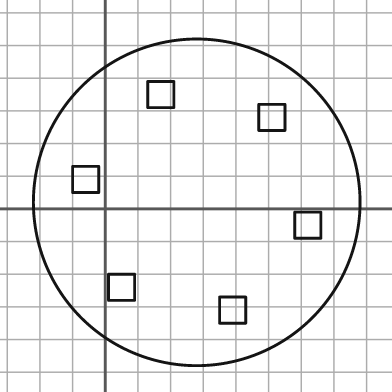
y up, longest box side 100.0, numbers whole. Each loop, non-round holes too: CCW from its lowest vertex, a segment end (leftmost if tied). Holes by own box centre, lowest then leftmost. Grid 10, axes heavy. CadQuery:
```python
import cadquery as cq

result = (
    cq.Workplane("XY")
    .moveTo(28.0, 2.0)
    .circle(50.0)
    .moveTo(35.0, -35.0)
    .lineTo(43.0, -35.0)
    .lineTo(43.0, -27.0)
    .lineTo(35.0, -27.0)
    .close()
    .moveTo(1.0, -28.0)
    .lineTo(9.0, -28.0)
    .lineTo(9.0, -20.0)
    .lineTo(1.0, -20.0)
    .close()
    .moveTo(58.0, -9.0)
    .lineTo(66.0, -9.0)
    .lineTo(66.0, -1.0)
    .lineTo(58.0, -1.0)
    .close()
    .moveTo(-10.0, 5.0)
    .lineTo(-2.0, 5.0)
    .lineTo(-2.0, 13.0)
    .lineTo(-10.0, 13.0)
    .close()
    .moveTo(47.0, 24.0)
    .lineTo(55.0, 24.0)
    .lineTo(55.0, 32.0)
    .lineTo(47.0, 32.0)
    .close()
    .moveTo(13.0, 31.0)
    .lineTo(21.0, 31.0)
    .lineTo(21.0, 39.0)
    .lineTo(13.0, 39.0)
    .close()
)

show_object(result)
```